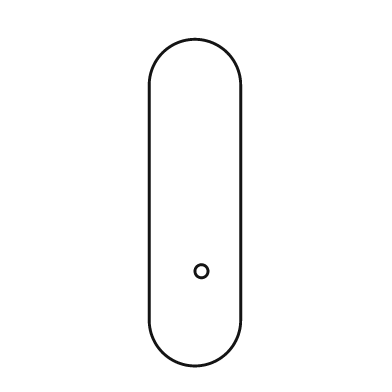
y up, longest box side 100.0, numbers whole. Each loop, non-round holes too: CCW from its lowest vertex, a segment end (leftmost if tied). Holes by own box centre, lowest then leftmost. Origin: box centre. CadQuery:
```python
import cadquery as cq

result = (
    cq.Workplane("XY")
    .moveTo(-14.0, -36.0)
    .threePointArc((0.0, -50.0), (14.0, -36.0))
    .lineTo(14.0, 36.0)
    .threePointArc((0.0, 50.0), (-14.0, 36.0))
    .close()
    .moveTo(2.0, -21.0)
    .circle(2.0)
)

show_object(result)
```